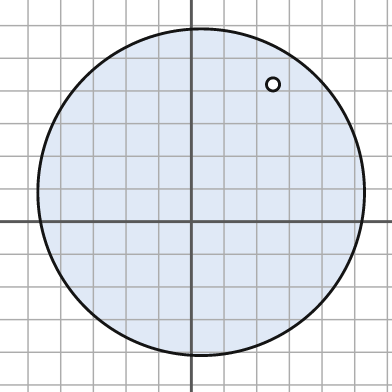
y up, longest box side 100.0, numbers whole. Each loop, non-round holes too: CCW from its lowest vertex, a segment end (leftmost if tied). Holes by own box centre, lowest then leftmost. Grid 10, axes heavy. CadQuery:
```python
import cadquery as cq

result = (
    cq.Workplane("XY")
    .moveTo(3.0, 9.0)
    .circle(50.0)
    .moveTo(25.0, 42.0)
    .circle(2.0)
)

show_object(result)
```